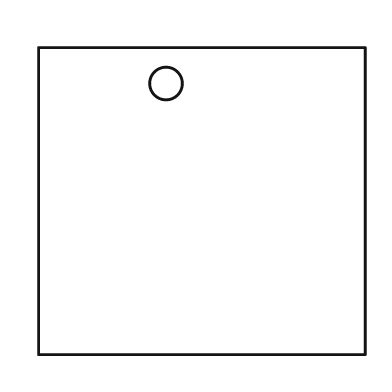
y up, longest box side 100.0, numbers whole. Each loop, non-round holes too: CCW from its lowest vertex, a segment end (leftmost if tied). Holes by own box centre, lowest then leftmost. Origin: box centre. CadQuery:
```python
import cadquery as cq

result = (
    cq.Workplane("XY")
    .moveTo(-50.0, -47.0)
    .lineTo(50.0, -47.0)
    .lineTo(50.0, 47.0)
    .lineTo(-50.0, 47.0)
    .close()
    .moveTo(-11.0, 36.0)
    .circle(5.0)
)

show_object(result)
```